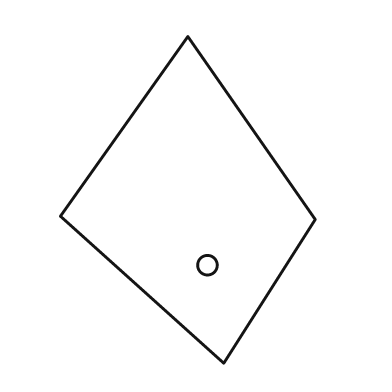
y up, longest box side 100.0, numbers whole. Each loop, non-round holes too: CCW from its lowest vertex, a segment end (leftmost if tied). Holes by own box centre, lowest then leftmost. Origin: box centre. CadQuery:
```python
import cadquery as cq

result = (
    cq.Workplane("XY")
    .moveTo(11.0, -50.0)
    .lineTo(39.0, -6.0)
    .lineTo(0.0, 50.0)
    .lineTo(-39.0, -5.0)
    .close()
    .moveTo(6.0, -20.0)
    .circle(3.0)
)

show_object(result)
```